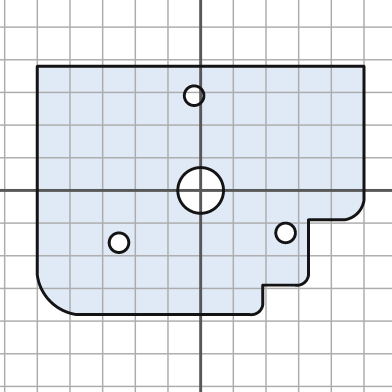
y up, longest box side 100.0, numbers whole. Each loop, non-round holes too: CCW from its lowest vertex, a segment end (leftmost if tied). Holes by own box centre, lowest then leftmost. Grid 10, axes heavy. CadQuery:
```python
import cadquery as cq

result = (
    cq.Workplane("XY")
    .moveTo(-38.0, -38.0)
    .lineTo(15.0, -38.0)
    .threePointArc((18.0, -37.0), (19.0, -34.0))
    .lineTo(19.0, -29.0)
    .lineTo(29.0, -29.0)
    .threePointArc((32.0, -28.0), (33.0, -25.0))
    .lineTo(33.0, -9.0)
    .lineTo(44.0, -9.0)
    .threePointArc((48.0, -7.0), (50.0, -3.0))
    .lineTo(50.0, 38.0)
    .lineTo(-50.0, 38.0)
    .lineTo(-50.0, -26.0)
    .threePointArc((-46.0, -34.0), (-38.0, -38.0))
    .close()
    .moveTo(-25.0, -16.0)
    .circle(3.0)
    .moveTo(26.0, -13.0)
    .circle(3.0)
    .moveTo(0.0, 0.0)
    .circle(7.0)
    .moveTo(-2.0, 29.0)
    .circle(3.0)
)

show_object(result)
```